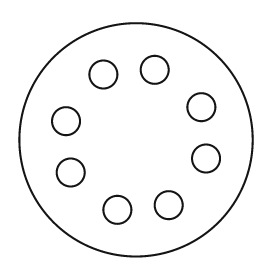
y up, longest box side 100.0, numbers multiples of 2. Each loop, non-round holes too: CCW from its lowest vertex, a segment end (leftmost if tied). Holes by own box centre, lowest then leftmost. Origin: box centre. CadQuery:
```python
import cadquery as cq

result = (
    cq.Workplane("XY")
    .moveTo(0.0, 0.0)
    .circle(50.0)
    .moveTo(-8.0, -30.0)
    .circle(6.0)
    .moveTo(14.0, -28.0)
    .circle(6.0)
    .moveTo(-28.0, -14.0)
    .circle(6.0)
    .moveTo(30.0, -8.0)
    .circle(6.0)
    .moveTo(-30.0, 8.0)
    .circle(6.0)
    .moveTo(28.0, 14.0)
    .circle(6.0)
    .moveTo(-14.0, 28.0)
    .circle(6.0)
    .moveTo(8.0, 30.0)
    .circle(6.0)
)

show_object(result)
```